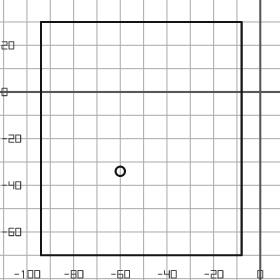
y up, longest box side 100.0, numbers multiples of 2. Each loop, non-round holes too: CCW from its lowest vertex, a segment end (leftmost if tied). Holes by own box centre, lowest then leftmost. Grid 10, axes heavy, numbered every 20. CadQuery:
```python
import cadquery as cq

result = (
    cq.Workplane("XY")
    .moveTo(-94.0, -70.0)
    .lineTo(-8.0, -70.0)
    .lineTo(-8.0, 30.0)
    .lineTo(-94.0, 30.0)
    .close()
    .moveTo(-60.0, -34.0)
    .circle(2.0)
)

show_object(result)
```